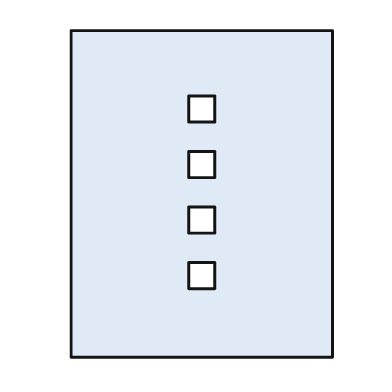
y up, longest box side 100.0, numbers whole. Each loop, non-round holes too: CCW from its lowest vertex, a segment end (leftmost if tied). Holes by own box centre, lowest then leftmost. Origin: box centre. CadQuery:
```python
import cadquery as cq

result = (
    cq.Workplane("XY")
    .moveTo(-40.0, -50.0)
    .lineTo(40.0, -50.0)
    .lineTo(40.0, 50.0)
    .lineTo(-40.0, 50.0)
    .close()
    .moveTo(-4.0, -29.0)
    .lineTo(4.0, -29.0)
    .lineTo(4.0, -21.0)
    .lineTo(-4.0, -21.0)
    .close()
    .moveTo(-4.0, -12.0)
    .lineTo(4.0, -12.0)
    .lineTo(4.0, -4.0)
    .lineTo(-4.0, -4.0)
    .close()
    .moveTo(-4.0, 5.0)
    .lineTo(4.0, 5.0)
    .lineTo(4.0, 13.0)
    .lineTo(-4.0, 13.0)
    .close()
    .moveTo(-4.0, 22.0)
    .lineTo(4.0, 22.0)
    .lineTo(4.0, 30.0)
    .lineTo(-4.0, 30.0)
    .close()
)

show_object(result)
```